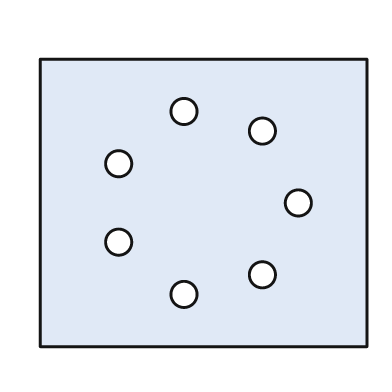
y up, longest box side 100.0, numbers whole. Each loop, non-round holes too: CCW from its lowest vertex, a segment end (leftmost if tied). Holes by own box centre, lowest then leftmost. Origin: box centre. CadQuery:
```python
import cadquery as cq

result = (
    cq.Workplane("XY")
    .moveTo(-50.0, -44.0)
    .lineTo(50.0, -44.0)
    .lineTo(50.0, 44.0)
    .lineTo(-50.0, 44.0)
    .close()
    .moveTo(-6.0, -28.0)
    .circle(4.0)
    .moveTo(18.0, -22.0)
    .circle(4.0)
    .moveTo(-26.0, -12.0)
    .circle(4.0)
    .moveTo(29.0, 0.0)
    .circle(4.0)
    .moveTo(-26.0, 12.0)
    .circle(4.0)
    .moveTo(18.0, 22.0)
    .circle(4.0)
    .moveTo(-6.0, 28.0)
    .circle(4.0)
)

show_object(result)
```